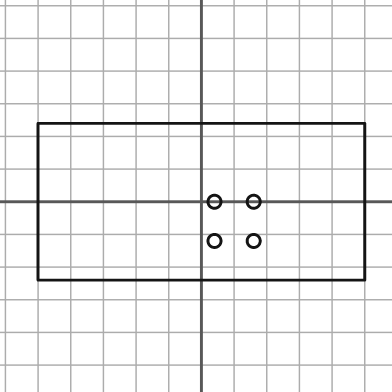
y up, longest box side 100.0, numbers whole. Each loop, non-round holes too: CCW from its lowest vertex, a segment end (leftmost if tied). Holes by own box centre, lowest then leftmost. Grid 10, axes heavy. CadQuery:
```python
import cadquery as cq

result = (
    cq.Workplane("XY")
    .moveTo(-50.0, -24.0)
    .lineTo(50.0, -24.0)
    .lineTo(50.0, 24.0)
    .lineTo(-50.0, 24.0)
    .close()
    .moveTo(4.0, -12.0)
    .circle(2.0)
    .moveTo(16.0, -12.0)
    .circle(2.0)
    .moveTo(4.0, 0.0)
    .circle(2.0)
    .moveTo(16.0, 0.0)
    .circle(2.0)
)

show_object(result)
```